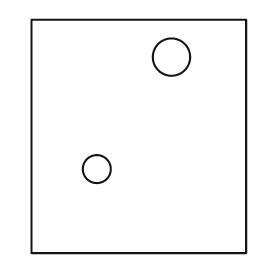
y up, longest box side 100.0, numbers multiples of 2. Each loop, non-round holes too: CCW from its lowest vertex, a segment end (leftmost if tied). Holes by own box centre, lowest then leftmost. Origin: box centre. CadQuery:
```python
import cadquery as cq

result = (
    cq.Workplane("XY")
    .moveTo(-46.0, -50.0)
    .lineTo(46.0, -50.0)
    .lineTo(46.0, 50.0)
    .lineTo(-46.0, 50.0)
    .close()
    .moveTo(-18.0, -14.0)
    .circle(6.0)
    .moveTo(14.0, 34.0)
    .circle(8.0)
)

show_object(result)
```